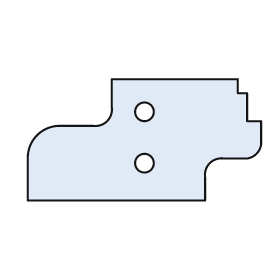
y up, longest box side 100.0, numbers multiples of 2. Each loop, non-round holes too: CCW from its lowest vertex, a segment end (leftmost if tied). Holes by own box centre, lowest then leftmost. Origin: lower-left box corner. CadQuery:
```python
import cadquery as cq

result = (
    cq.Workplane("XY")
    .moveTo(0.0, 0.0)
    .lineTo(76.0, 0.0)
    .lineTo(76.0, 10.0)
    .threePointArc((78.0, 16.0), (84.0, 18.0))
    .lineTo(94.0, 18.0)
    .threePointArc((98.0, 20.0), (100.0, 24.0))
    .lineTo(100.0, 34.0)
    .lineTo(94.0, 34.0)
    .lineTo(94.0, 46.0)
    .lineTo(90.0, 46.0)
    .lineTo(90.0, 52.0)
    .lineTo(36.0, 52.0)
    .lineTo(36.0, 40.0)
    .threePointArc((34.0, 34.0), (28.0, 32.0))
    .lineTo(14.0, 32.0)
    .threePointArc((4.0, 28.0), (0.0, 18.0))
    .close()
    .moveTo(50.0, 16.0)
    .circle(4.0)
    .moveTo(50.0, 38.0)
    .circle(4.0)
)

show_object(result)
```